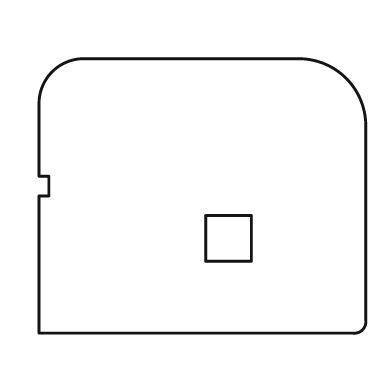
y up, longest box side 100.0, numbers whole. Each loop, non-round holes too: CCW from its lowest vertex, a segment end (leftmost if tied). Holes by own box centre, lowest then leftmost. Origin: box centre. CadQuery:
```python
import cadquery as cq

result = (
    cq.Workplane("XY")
    .moveTo(-50.0, -42.0)
    .lineTo(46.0, -42.0)
    .threePointArc((49.0, -41.0), (50.0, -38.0))
    .lineTo(50.0, 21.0)
    .threePointArc((44.0, 36.0), (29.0, 42.0))
    .lineTo(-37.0, 42.0)
    .threePointArc((-46.0, 38.0), (-50.0, 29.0))
    .lineTo(-50.0, 6.0)
    .lineTo(-47.0, 6.0)
    .lineTo(-47.0, 0.0)
    .lineTo(-50.0, 0.0)
    .close()
    .moveTo(1.0, -20.0)
    .lineTo(15.0, -20.0)
    .lineTo(15.0, -6.0)
    .lineTo(1.0, -6.0)
    .close()
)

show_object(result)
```